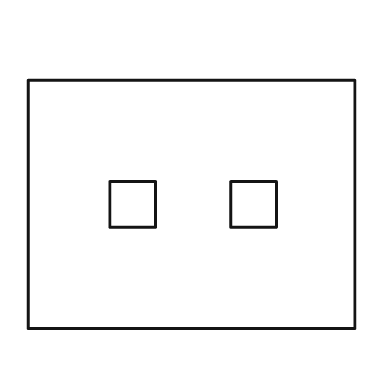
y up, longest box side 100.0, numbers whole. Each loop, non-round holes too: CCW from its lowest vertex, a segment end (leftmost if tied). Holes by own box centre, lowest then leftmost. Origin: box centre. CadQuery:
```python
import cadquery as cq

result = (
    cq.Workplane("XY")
    .moveTo(-50.0, -38.0)
    .lineTo(50.0, -38.0)
    .lineTo(50.0, 38.0)
    .lineTo(-50.0, 38.0)
    .close()
    .moveTo(-25.0, -7.0)
    .lineTo(-11.0, -7.0)
    .lineTo(-11.0, 7.0)
    .lineTo(-25.0, 7.0)
    .close()
    .moveTo(12.0, -7.0)
    .lineTo(26.0, -7.0)
    .lineTo(26.0, 7.0)
    .lineTo(12.0, 7.0)
    .close()
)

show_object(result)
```